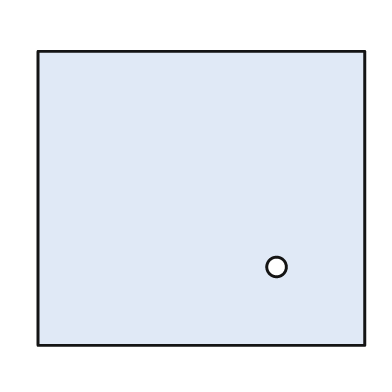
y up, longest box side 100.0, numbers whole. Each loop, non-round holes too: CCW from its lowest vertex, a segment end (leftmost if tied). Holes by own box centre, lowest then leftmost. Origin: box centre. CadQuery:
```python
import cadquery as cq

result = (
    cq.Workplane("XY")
    .moveTo(-50.0, -45.0)
    .lineTo(50.0, -45.0)
    .lineTo(50.0, 45.0)
    .lineTo(-50.0, 45.0)
    .close()
    .moveTo(23.0, -21.0)
    .circle(3.0)
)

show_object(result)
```